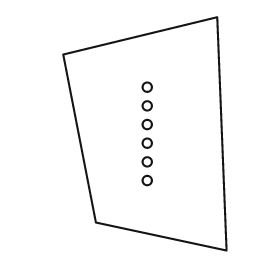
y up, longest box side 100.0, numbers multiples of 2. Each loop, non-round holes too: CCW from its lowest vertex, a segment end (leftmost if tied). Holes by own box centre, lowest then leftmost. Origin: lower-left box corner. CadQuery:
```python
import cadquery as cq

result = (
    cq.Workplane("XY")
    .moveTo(70.0, 0.0)
    .lineTo(66.0, 100.0)
    .lineTo(0.0, 84.0)
    .lineTo(14.0, 12.0)
    .close()
    .moveTo(36.0, 30.0)
    .circle(2.0)
    .moveTo(36.0, 38.0)
    .circle(2.0)
    .moveTo(36.0, 46.0)
    .circle(2.0)
    .moveTo(36.0, 54.0)
    .circle(2.0)
    .moveTo(36.0, 62.0)
    .circle(2.0)
    .moveTo(36.0, 70.0)
    .circle(2.0)
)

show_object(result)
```